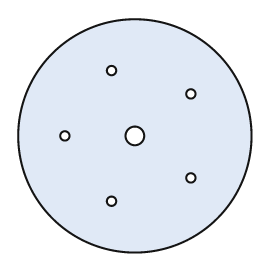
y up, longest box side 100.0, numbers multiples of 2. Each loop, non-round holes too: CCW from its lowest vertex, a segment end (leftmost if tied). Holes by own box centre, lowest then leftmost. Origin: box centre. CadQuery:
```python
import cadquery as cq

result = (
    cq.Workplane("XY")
    .moveTo(0.0, 0.0)
    .circle(50.0)
    .moveTo(-10.0, -28.0)
    .circle(2.0)
    .moveTo(24.0, -18.0)
    .circle(2.0)
    .moveTo(-30.0, 0.0)
    .circle(2.0)
    .moveTo(0.0, 0.0)
    .circle(4.0)
    .moveTo(24.0, 18.0)
    .circle(2.0)
    .moveTo(-10.0, 28.0)
    .circle(2.0)
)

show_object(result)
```